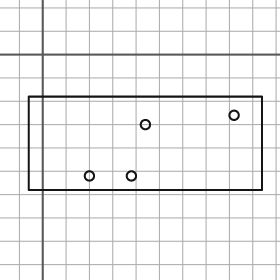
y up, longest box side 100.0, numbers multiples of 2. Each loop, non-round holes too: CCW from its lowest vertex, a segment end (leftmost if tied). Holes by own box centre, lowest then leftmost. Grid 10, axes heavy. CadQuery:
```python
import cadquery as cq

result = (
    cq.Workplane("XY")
    .moveTo(-6.0, -58.0)
    .lineTo(94.0, -58.0)
    .lineTo(94.0, -18.0)
    .lineTo(-6.0, -18.0)
    .close()
    .moveTo(20.0, -52.0)
    .circle(2.0)
    .moveTo(38.0, -52.0)
    .circle(2.0)
    .moveTo(44.0, -30.0)
    .circle(2.0)
    .moveTo(82.0, -26.0)
    .circle(2.0)
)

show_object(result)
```